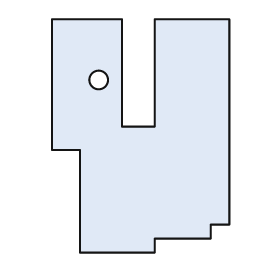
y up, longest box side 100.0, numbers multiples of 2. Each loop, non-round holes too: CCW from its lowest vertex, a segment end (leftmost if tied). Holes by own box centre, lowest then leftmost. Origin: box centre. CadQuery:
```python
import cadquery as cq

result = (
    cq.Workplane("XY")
    .moveTo(-26.0, -50.0)
    .lineTo(6.0, -50.0)
    .lineTo(6.0, -44.0)
    .lineTo(30.0, -44.0)
    .lineTo(30.0, -38.0)
    .lineTo(38.0, -38.0)
    .lineTo(38.0, 50.0)
    .lineTo(6.0, 50.0)
    .lineTo(6.0, 4.0)
    .lineTo(-8.0, 4.0)
    .lineTo(-8.0, 50.0)
    .lineTo(-38.0, 50.0)
    .lineTo(-38.0, -6.0)
    .lineTo(-26.0, -6.0)
    .close()
    .moveTo(-18.0, 24.0)
    .circle(4.0)
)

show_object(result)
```